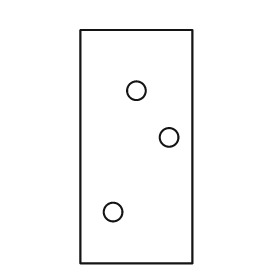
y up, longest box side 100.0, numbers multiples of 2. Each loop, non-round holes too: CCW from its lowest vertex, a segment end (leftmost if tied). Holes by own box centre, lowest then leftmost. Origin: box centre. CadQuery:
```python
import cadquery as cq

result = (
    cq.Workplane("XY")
    .moveTo(-24.0, -50.0)
    .lineTo(24.0, -50.0)
    .lineTo(24.0, 50.0)
    .lineTo(-24.0, 50.0)
    .close()
    .moveTo(-10.0, -28.0)
    .circle(4.0)
    .moveTo(14.0, 4.0)
    .circle(4.0)
    .moveTo(0.0, 24.0)
    .circle(4.0)
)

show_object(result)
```